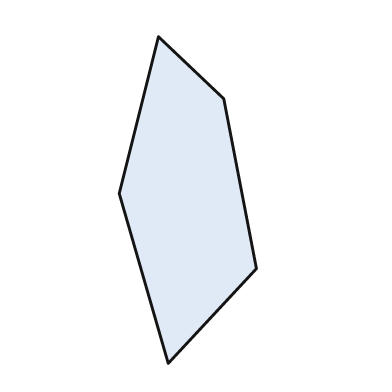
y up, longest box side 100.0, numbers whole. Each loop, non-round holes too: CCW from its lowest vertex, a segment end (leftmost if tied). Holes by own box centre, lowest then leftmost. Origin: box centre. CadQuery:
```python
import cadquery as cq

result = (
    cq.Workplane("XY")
    .moveTo(-6.0, -50.0)
    .lineTo(21.0, -21.0)
    .lineTo(11.0, 31.0)
    .lineTo(-9.0, 50.0)
    .lineTo(-21.0, 2.0)
    .close()
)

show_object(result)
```